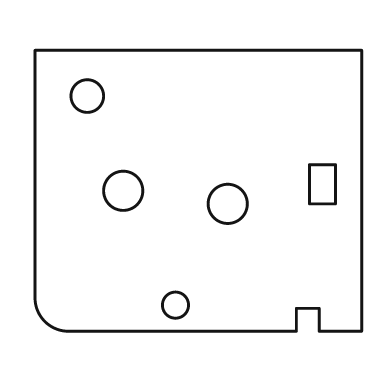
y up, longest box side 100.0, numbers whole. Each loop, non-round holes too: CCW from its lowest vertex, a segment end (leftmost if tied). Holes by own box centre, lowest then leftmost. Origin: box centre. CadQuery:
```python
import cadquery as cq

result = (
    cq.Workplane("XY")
    .moveTo(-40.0, -43.0)
    .lineTo(30.0, -43.0)
    .lineTo(30.0, -36.0)
    .lineTo(37.0, -36.0)
    .lineTo(37.0, -43.0)
    .lineTo(50.0, -43.0)
    .lineTo(50.0, 43.0)
    .lineTo(-50.0, 43.0)
    .lineTo(-50.0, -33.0)
    .threePointArc((-47.0, -40.0), (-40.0, -43.0))
    .close()
    .moveTo(-7.0, -35.0)
    .circle(4.0)
    .moveTo(9.0, -4.0)
    .circle(6.0)
    .moveTo(-23.0, 0.0)
    .circle(6.0)
    .moveTo(34.0, -4.0)
    .lineTo(42.0, -4.0)
    .lineTo(42.0, 8.0)
    .lineTo(34.0, 8.0)
    .close()
    .moveTo(-34.0, 29.0)
    .circle(5.0)
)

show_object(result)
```